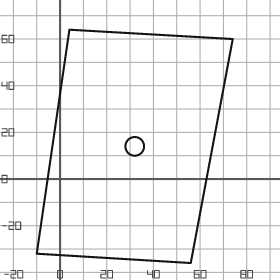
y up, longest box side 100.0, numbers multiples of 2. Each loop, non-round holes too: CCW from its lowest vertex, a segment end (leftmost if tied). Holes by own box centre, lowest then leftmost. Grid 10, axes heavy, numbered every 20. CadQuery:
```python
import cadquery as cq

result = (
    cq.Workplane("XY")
    .moveTo(56.0, -36.0)
    .lineTo(74.0, 60.0)
    .lineTo(4.0, 64.0)
    .lineTo(-10.0, -32.0)
    .close()
    .moveTo(32.0, 14.0)
    .circle(4.0)
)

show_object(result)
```